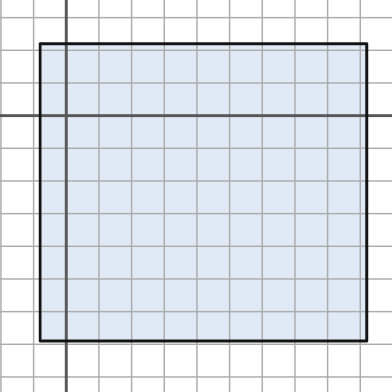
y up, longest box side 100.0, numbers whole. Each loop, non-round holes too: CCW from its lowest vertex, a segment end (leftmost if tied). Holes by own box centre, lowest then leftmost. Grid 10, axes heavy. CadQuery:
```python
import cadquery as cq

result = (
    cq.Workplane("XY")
    .moveTo(-8.0, -69.0)
    .lineTo(92.0, -69.0)
    .lineTo(92.0, 22.0)
    .lineTo(-8.0, 22.0)
    .close()
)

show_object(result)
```